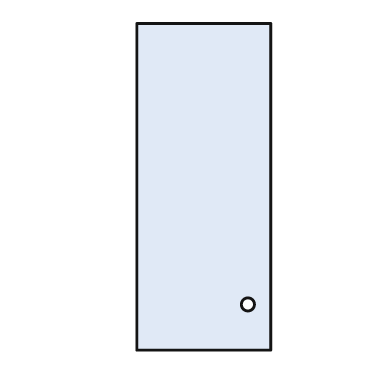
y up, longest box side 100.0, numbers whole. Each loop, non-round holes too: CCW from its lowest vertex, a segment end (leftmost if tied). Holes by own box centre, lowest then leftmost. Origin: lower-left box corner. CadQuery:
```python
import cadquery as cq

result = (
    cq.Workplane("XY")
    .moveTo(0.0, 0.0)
    .lineTo(41.0, 0.0)
    .lineTo(41.0, 100.0)
    .lineTo(0.0, 100.0)
    .close()
    .moveTo(34.0, 14.0)
    .circle(2.0)
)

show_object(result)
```